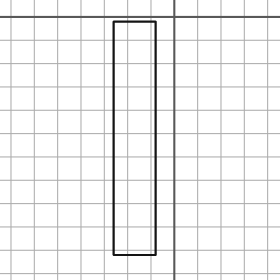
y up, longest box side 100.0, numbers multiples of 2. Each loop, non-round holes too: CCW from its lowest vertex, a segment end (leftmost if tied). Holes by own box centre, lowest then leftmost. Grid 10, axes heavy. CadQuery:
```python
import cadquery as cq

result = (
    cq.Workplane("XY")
    .moveTo(-26.0, -102.0)
    .lineTo(-8.0, -102.0)
    .lineTo(-8.0, -2.0)
    .lineTo(-26.0, -2.0)
    .close()
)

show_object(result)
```